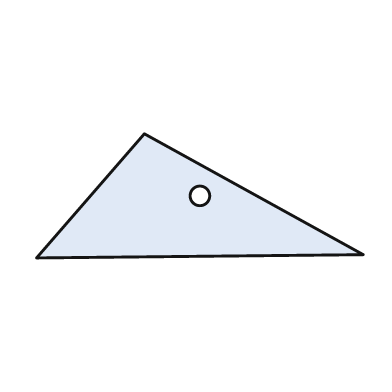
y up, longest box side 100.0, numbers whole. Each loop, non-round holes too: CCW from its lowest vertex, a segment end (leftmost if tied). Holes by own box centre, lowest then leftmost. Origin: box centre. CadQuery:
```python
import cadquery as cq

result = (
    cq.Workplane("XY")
    .moveTo(-50.0, -19.0)
    .lineTo(50.0, -18.0)
    .lineTo(-17.0, 19.0)
    .close()
    .moveTo(0.0, 0.0)
    .circle(3.0)
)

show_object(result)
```